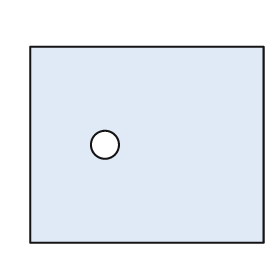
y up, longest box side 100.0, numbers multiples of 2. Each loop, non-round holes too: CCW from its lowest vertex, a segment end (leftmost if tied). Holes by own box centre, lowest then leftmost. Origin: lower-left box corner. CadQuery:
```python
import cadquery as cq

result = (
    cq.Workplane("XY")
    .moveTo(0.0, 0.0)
    .lineTo(100.0, 0.0)
    .lineTo(100.0, 84.0)
    .lineTo(0.0, 84.0)
    .close()
    .moveTo(32.0, 42.0)
    .circle(6.0)
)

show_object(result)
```